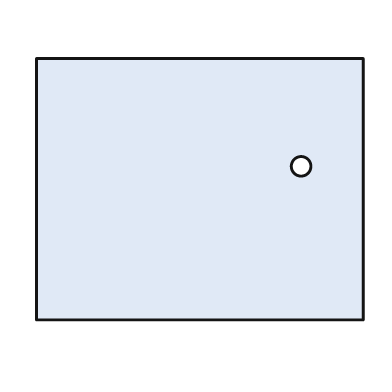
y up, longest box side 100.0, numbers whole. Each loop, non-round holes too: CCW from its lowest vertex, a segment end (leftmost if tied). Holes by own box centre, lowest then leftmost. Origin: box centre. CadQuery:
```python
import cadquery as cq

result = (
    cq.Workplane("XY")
    .moveTo(-50.0, -40.0)
    .lineTo(50.0, -40.0)
    .lineTo(50.0, 40.0)
    .lineTo(-50.0, 40.0)
    .close()
    .moveTo(31.0, 7.0)
    .circle(3.0)
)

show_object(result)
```